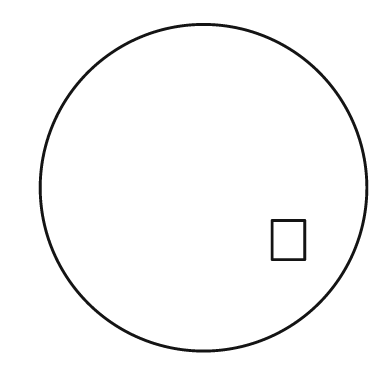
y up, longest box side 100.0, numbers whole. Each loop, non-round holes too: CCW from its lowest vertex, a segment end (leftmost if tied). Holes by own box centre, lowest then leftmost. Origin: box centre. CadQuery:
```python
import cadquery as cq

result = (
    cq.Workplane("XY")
    .moveTo(0.0, 0.0)
    .circle(50.0)
    .moveTo(21.0, -22.0)
    .lineTo(31.0, -22.0)
    .lineTo(31.0, -10.0)
    .lineTo(21.0, -10.0)
    .close()
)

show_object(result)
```